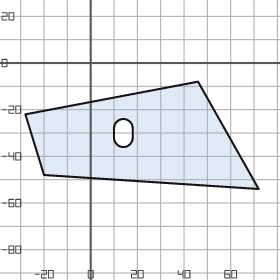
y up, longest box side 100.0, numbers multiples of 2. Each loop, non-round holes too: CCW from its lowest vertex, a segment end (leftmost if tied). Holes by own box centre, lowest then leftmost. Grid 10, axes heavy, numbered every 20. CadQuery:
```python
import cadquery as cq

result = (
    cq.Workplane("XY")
    .moveTo(72.0, -54.0)
    .lineTo(46.0, -8.0)
    .lineTo(-28.0, -22.0)
    .lineTo(-20.0, -48.0)
    .close()
    .moveTo(10.0, -32.0)
    .threePointArc((14.0, -36.0), (18.0, -32.0))
    .lineTo(18.0, -28.0)
    .threePointArc((14.0, -24.0), (10.0, -28.0))
    .close()
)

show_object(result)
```